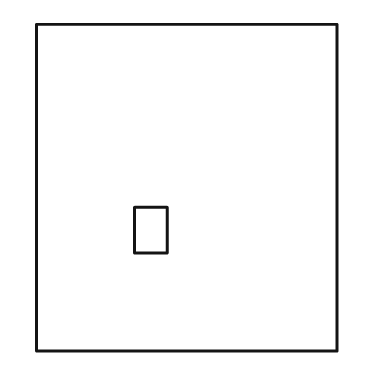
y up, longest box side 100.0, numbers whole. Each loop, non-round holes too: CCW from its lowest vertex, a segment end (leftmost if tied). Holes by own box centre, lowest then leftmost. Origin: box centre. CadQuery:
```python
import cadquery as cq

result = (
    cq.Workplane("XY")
    .moveTo(-46.0, -50.0)
    .lineTo(46.0, -50.0)
    .lineTo(46.0, 50.0)
    .lineTo(-46.0, 50.0)
    .close()
    .moveTo(-16.0, -20.0)
    .lineTo(-6.0, -20.0)
    .lineTo(-6.0, -6.0)
    .lineTo(-16.0, -6.0)
    .close()
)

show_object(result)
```